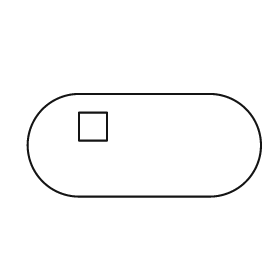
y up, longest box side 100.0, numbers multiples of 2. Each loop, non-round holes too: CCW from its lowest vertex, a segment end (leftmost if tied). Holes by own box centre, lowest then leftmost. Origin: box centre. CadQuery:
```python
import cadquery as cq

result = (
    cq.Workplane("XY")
    .moveTo(-28.0, -22.0)
    .lineTo(28.0, -22.0)
    .threePointArc((50.0, 0.0), (28.0, 22.0))
    .lineTo(-28.0, 22.0)
    .threePointArc((-50.0, 0.0), (-28.0, -22.0))
    .close()
    .moveTo(-28.0, 2.0)
    .lineTo(-16.0, 2.0)
    .lineTo(-16.0, 14.0)
    .lineTo(-28.0, 14.0)
    .close()
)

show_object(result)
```